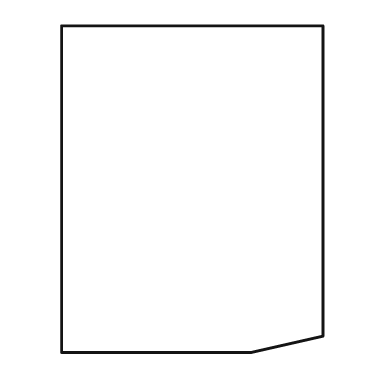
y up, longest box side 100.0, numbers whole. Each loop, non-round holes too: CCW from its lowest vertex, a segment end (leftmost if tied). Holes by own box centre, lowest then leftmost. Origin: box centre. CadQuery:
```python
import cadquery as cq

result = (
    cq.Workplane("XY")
    .moveTo(-40.0, -50.0)
    .lineTo(18.0, -50.0)
    .lineTo(40.0, -45.0)
    .lineTo(40.0, 50.0)
    .lineTo(-40.0, 50.0)
    .close()
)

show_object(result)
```